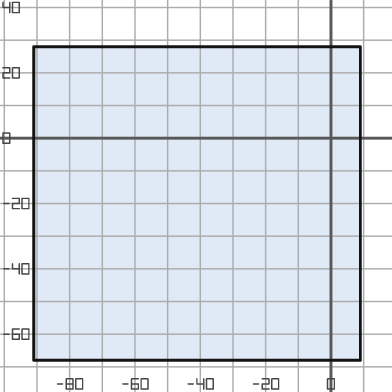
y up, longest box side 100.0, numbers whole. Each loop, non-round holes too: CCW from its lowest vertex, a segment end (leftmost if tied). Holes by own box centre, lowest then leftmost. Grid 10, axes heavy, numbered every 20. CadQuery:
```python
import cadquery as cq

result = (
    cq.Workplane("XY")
    .moveTo(-91.0, -68.0)
    .lineTo(9.0, -68.0)
    .lineTo(9.0, 28.0)
    .lineTo(-91.0, 28.0)
    .close()
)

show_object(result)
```